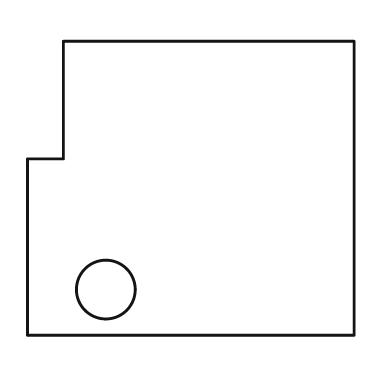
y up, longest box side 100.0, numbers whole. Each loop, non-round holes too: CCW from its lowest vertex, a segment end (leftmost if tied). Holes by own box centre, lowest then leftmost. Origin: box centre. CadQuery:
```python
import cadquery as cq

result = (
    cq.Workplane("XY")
    .moveTo(-50.0, -45.0)
    .lineTo(50.0, -45.0)
    .lineTo(50.0, 45.0)
    .lineTo(-39.0, 45.0)
    .lineTo(-39.0, 9.0)
    .lineTo(-50.0, 9.0)
    .close()
    .moveTo(-26.0, -31.0)
    .circle(9.0)
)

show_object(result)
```